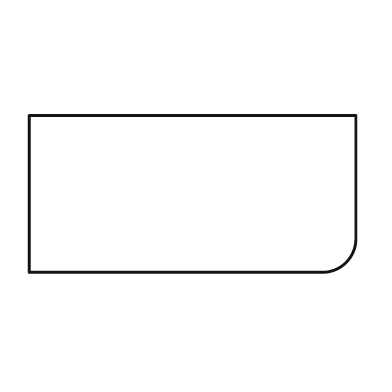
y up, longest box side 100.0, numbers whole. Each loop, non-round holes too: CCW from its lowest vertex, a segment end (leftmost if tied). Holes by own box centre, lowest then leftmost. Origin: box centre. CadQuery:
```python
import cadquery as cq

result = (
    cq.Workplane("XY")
    .moveTo(-50.0, -24.0)
    .lineTo(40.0, -24.0)
    .threePointArc((47.0, -21.0), (50.0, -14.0))
    .lineTo(50.0, 24.0)
    .lineTo(-50.0, 24.0)
    .close()
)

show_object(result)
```